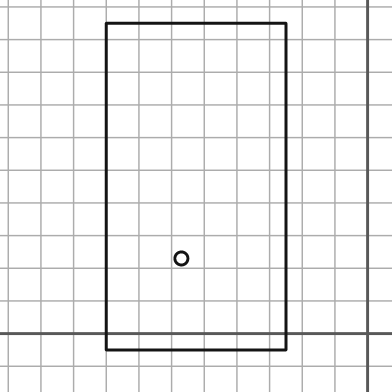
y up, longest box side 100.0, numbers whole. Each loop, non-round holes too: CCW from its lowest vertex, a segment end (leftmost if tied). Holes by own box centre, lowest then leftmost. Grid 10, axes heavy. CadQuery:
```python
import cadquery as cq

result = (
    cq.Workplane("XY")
    .moveTo(-80.0, -5.0)
    .lineTo(-25.0, -5.0)
    .lineTo(-25.0, 95.0)
    .lineTo(-80.0, 95.0)
    .close()
    .moveTo(-57.0, 23.0)
    .circle(2.0)
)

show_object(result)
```